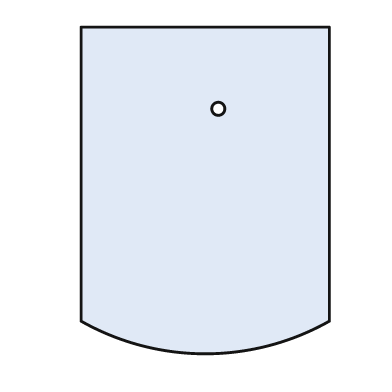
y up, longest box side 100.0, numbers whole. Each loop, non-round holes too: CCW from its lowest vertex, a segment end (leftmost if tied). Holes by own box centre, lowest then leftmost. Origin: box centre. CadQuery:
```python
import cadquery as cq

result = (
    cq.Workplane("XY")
    .moveTo(-38.0, -40.0)
    .threePointArc((0.0, -50.0), (38.0, -40.0))
    .lineTo(38.0, 50.0)
    .lineTo(-38.0, 50.0)
    .close()
    .moveTo(4.0, 25.0)
    .circle(2.0)
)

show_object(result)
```